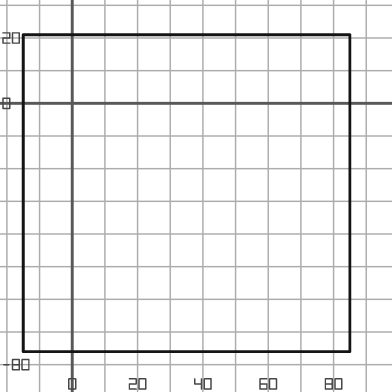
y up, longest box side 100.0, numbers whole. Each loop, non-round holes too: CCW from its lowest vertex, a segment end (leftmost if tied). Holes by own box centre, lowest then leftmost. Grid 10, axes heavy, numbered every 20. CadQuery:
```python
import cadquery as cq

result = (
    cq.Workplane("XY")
    .moveTo(-15.0, -76.0)
    .lineTo(85.0, -76.0)
    .lineTo(85.0, 21.0)
    .lineTo(-15.0, 21.0)
    .close()
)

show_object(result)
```